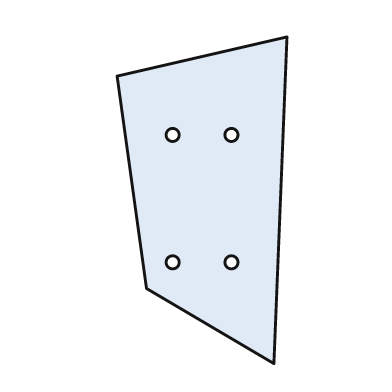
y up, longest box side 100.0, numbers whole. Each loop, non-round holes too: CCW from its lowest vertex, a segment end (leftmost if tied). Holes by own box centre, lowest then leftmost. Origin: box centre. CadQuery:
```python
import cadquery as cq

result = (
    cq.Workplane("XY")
    .moveTo(22.0, -50.0)
    .lineTo(26.0, 50.0)
    .lineTo(-26.0, 38.0)
    .lineTo(-17.0, -27.0)
    .close()
    .moveTo(-9.0, -19.0)
    .circle(2.0)
    .moveTo(9.0, -19.0)
    .circle(2.0)
    .moveTo(-9.0, 20.0)
    .circle(2.0)
    .moveTo(9.0, 20.0)
    .circle(2.0)
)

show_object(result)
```